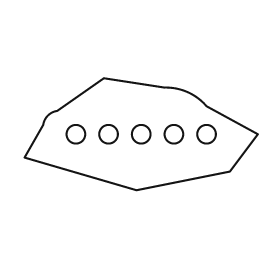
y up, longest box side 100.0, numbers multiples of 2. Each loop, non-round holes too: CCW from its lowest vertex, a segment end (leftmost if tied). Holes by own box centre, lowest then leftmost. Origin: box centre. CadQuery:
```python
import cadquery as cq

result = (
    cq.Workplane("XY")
    .moveTo(-2.0, -24.0)
    .lineTo(38.0, -16.0)
    .lineTo(50.0, 0.0)
    .lineTo(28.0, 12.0)
    .threePointArc((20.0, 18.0), (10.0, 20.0))
    .lineTo(-16.0, 24.0)
    .lineTo(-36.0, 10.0)
    .threePointArc((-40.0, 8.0), (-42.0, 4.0))
    .lineTo(-50.0, -10.0)
    .close()
    .moveTo(-28.0, 0.0)
    .circle(4.0)
    .moveTo(-14.0, 0.0)
    .circle(4.0)
    .moveTo(0.0, 0.0)
    .circle(4.0)
    .moveTo(14.0, 0.0)
    .circle(4.0)
    .moveTo(28.0, 0.0)
    .circle(4.0)
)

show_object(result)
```